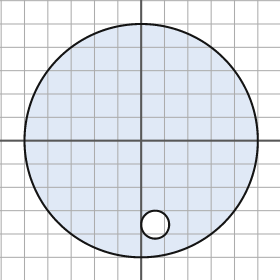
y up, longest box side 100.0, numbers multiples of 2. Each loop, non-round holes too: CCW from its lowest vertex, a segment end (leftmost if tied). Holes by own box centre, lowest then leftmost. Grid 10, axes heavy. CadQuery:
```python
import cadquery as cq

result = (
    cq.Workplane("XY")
    .moveTo(0.0, 0.0)
    .circle(50.0)
    .moveTo(6.0, -36.0)
    .circle(6.0)
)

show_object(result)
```